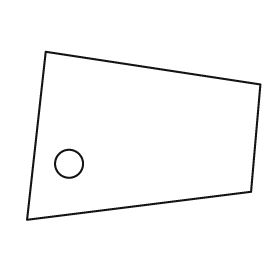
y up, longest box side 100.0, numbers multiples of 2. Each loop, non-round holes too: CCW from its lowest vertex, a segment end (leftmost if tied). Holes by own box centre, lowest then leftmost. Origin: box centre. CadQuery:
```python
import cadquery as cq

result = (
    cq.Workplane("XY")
    .moveTo(-50.0, -36.0)
    .lineTo(46.0, -24.0)
    .lineTo(50.0, 22.0)
    .lineTo(-42.0, 36.0)
    .close()
    .moveTo(-32.0, -12.0)
    .circle(6.0)
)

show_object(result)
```